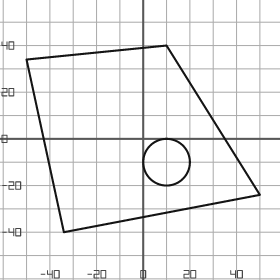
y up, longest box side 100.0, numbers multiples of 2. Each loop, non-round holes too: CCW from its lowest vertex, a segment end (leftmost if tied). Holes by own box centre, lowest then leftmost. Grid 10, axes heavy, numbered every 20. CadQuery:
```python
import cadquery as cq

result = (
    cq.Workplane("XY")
    .moveTo(-34.0, -40.0)
    .lineTo(50.0, -24.0)
    .lineTo(10.0, 40.0)
    .lineTo(-50.0, 34.0)
    .close()
    .moveTo(10.0, -10.0)
    .circle(10.0)
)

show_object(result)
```